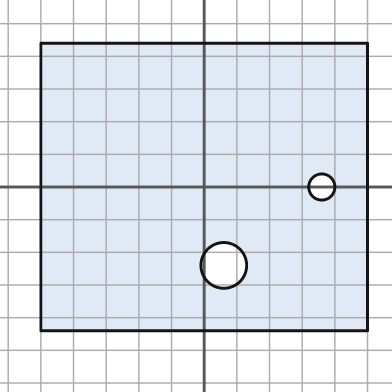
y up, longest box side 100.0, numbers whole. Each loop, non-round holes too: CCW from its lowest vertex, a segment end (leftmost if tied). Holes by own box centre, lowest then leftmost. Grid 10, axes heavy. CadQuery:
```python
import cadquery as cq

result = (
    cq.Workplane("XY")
    .moveTo(-50.0, -44.0)
    .lineTo(50.0, -44.0)
    .lineTo(50.0, 44.0)
    .lineTo(-50.0, 44.0)
    .close()
    .moveTo(6.0, -24.0)
    .circle(7.0)
    .moveTo(36.0, 0.0)
    .circle(4.0)
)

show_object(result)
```